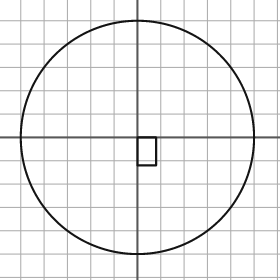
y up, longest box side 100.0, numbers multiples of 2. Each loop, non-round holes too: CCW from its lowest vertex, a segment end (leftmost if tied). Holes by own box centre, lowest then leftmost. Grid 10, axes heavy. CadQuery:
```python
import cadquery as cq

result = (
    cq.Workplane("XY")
    .moveTo(0.0, 0.0)
    .circle(50.0)
    .moveTo(0.0, -12.0)
    .lineTo(8.0, -12.0)
    .lineTo(8.0, 0.0)
    .lineTo(0.0, 0.0)
    .close()
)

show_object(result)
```